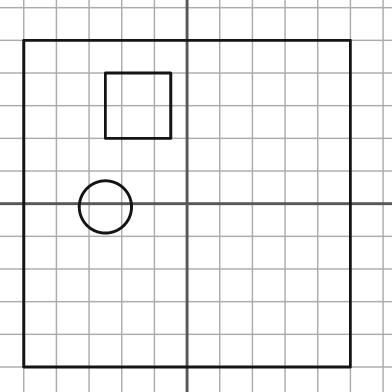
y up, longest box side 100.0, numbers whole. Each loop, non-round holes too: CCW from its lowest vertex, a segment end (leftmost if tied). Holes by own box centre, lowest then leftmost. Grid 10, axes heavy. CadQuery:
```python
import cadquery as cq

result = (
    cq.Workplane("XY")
    .moveTo(-50.0, -50.0)
    .lineTo(50.0, -50.0)
    .lineTo(50.0, 50.0)
    .lineTo(-50.0, 50.0)
    .close()
    .moveTo(-25.0, -1.0)
    .circle(8.0)
    .moveTo(-25.0, 20.0)
    .lineTo(-5.0, 20.0)
    .lineTo(-5.0, 40.0)
    .lineTo(-25.0, 40.0)
    .close()
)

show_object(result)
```